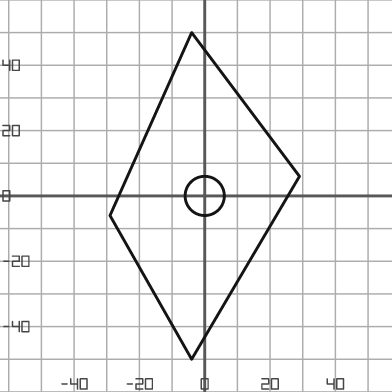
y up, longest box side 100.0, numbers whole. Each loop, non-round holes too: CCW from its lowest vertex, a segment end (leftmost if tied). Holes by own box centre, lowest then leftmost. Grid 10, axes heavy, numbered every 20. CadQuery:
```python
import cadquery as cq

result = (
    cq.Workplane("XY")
    .moveTo(-4.0, -50.0)
    .lineTo(29.0, 6.0)
    .lineTo(-4.0, 50.0)
    .lineTo(-29.0, -6.0)
    .close()
    .moveTo(0.0, 0.0)
    .circle(6.0)
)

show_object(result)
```